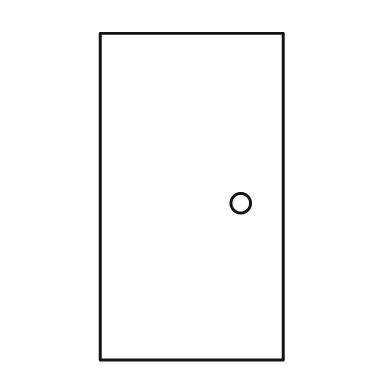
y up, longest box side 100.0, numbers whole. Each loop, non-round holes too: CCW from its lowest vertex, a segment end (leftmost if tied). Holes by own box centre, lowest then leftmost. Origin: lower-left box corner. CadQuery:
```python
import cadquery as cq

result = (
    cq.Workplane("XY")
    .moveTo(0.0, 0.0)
    .lineTo(56.0, 0.0)
    .lineTo(56.0, 100.0)
    .lineTo(0.0, 100.0)
    .close()
    .moveTo(43.0, 48.0)
    .circle(3.0)
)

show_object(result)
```